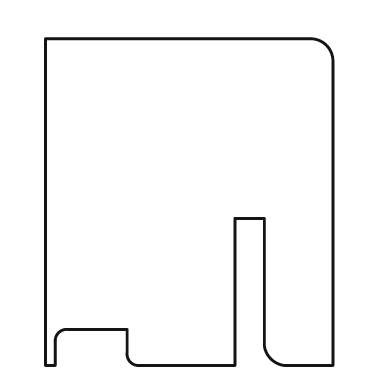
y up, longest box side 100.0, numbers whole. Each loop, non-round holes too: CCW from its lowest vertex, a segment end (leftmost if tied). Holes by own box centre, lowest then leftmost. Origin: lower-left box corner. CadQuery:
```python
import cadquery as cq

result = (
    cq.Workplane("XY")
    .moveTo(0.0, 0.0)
    .lineTo(3.0, 0.0)
    .lineTo(3.0, 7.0)
    .threePointArc((4.0, 10.0), (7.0, 11.0))
    .lineTo(25.0, 11.0)
    .lineTo(25.0, 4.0)
    .threePointArc((26.0, 1.0), (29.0, 0.0))
    .lineTo(58.0, 0.0)
    .lineTo(58.0, 45.0)
    .lineTo(67.0, 45.0)
    .lineTo(67.0, 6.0)
    .threePointArc((69.0, 2.0), (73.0, 0.0))
    .lineTo(88.0, 0.0)
    .lineTo(88.0, 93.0)
    .threePointArc((86.0, 98.0), (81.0, 100.0))
    .lineTo(0.0, 100.0)
    .close()
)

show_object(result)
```